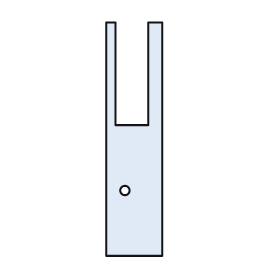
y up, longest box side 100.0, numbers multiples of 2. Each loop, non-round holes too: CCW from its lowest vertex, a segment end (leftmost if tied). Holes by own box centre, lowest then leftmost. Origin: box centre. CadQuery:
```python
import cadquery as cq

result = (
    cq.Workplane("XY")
    .moveTo(-12.0, -50.0)
    .lineTo(12.0, -50.0)
    .lineTo(12.0, 50.0)
    .lineTo(6.0, 50.0)
    .lineTo(6.0, 6.0)
    .lineTo(-8.0, 6.0)
    .lineTo(-8.0, 50.0)
    .lineTo(-12.0, 50.0)
    .close()
    .moveTo(-4.0, -22.0)
    .circle(2.0)
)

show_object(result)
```